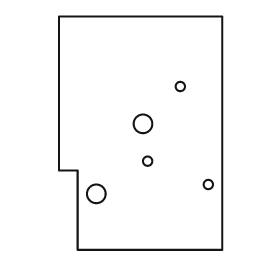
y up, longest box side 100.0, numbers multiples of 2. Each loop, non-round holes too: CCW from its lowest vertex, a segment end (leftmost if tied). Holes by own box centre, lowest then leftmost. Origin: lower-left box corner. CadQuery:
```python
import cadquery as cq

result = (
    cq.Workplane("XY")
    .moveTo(8.0, 0.0)
    .lineTo(70.0, 0.0)
    .lineTo(70.0, 100.0)
    .lineTo(0.0, 100.0)
    .lineTo(0.0, 34.0)
    .lineTo(8.0, 34.0)
    .close()
    .moveTo(16.0, 24.0)
    .circle(4.0)
    .moveTo(64.0, 28.0)
    .circle(2.0)
    .moveTo(38.0, 38.0)
    .circle(2.0)
    .moveTo(36.0, 54.0)
    .circle(4.0)
    .moveTo(52.0, 70.0)
    .circle(2.0)
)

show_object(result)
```